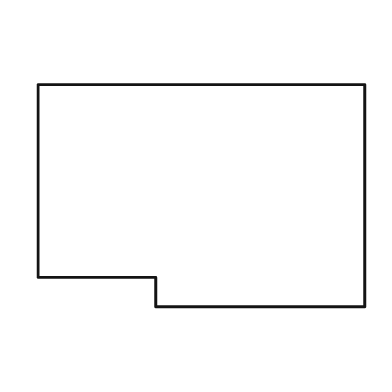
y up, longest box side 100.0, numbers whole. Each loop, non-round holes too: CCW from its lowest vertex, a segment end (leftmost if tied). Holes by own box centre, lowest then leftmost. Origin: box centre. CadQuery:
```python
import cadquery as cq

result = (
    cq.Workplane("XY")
    .moveTo(-14.0, -34.0)
    .lineTo(50.0, -34.0)
    .lineTo(50.0, 34.0)
    .lineTo(-50.0, 34.0)
    .lineTo(-50.0, -25.0)
    .lineTo(-14.0, -25.0)
    .close()
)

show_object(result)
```